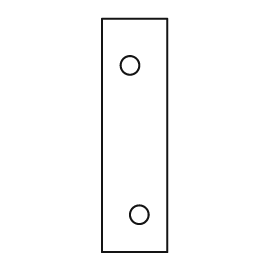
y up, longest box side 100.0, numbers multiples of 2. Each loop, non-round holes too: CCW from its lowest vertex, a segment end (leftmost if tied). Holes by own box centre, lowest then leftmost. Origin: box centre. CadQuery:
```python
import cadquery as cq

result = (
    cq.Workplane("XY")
    .moveTo(-14.0, -50.0)
    .lineTo(14.0, -50.0)
    .lineTo(14.0, 50.0)
    .lineTo(-14.0, 50.0)
    .close()
    .moveTo(2.0, -34.0)
    .circle(4.0)
    .moveTo(-2.0, 30.0)
    .circle(4.0)
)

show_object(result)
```